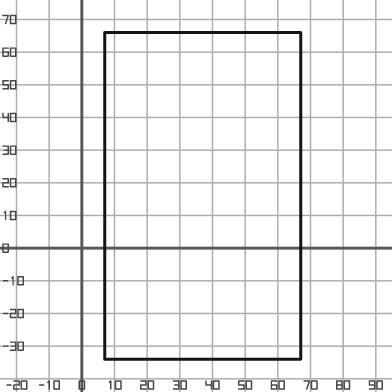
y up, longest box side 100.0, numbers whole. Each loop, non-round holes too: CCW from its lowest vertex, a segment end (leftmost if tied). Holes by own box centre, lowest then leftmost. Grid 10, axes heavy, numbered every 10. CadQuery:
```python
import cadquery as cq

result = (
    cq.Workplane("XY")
    .moveTo(7.0, -34.0)
    .lineTo(67.0, -34.0)
    .lineTo(67.0, 66.0)
    .lineTo(7.0, 66.0)
    .close()
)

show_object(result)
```